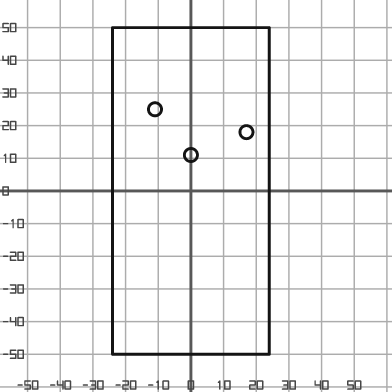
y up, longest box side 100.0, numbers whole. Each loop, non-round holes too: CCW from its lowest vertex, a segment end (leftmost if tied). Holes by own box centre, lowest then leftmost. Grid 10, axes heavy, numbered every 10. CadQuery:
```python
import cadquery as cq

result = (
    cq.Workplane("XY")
    .moveTo(-24.0, -50.0)
    .lineTo(24.0, -50.0)
    .lineTo(24.0, 50.0)
    .lineTo(-24.0, 50.0)
    .close()
    .moveTo(0.0, 11.0)
    .circle(2.0)
    .moveTo(17.0, 18.0)
    .circle(2.0)
    .moveTo(-11.0, 25.0)
    .circle(2.0)
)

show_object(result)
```